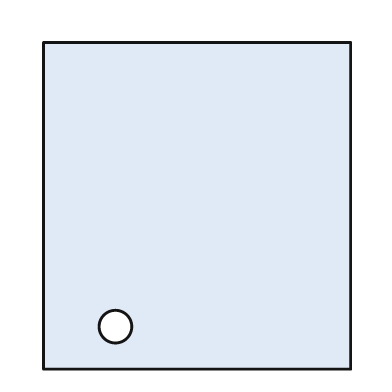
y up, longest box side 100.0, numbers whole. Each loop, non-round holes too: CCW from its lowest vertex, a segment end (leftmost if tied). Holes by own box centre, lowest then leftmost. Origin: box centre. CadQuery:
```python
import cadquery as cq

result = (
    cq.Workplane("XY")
    .moveTo(-47.0, -50.0)
    .lineTo(47.0, -50.0)
    .lineTo(47.0, 50.0)
    .lineTo(-47.0, 50.0)
    .close()
    .moveTo(-25.0, -37.0)
    .circle(5.0)
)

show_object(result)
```